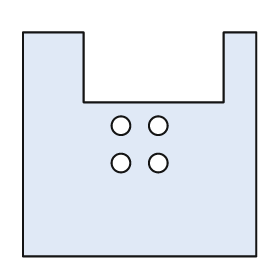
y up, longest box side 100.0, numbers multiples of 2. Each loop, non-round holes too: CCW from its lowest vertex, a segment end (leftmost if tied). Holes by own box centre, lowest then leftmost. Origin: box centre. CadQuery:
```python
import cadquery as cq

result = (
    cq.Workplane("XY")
    .moveTo(-50.0, -48.0)
    .lineTo(50.0, -48.0)
    .lineTo(50.0, 48.0)
    .lineTo(36.0, 48.0)
    .lineTo(36.0, 18.0)
    .lineTo(-24.0, 18.0)
    .lineTo(-24.0, 48.0)
    .lineTo(-50.0, 48.0)
    .close()
    .moveTo(-8.0, -8.0)
    .circle(4.0)
    .moveTo(8.0, -8.0)
    .circle(4.0)
    .moveTo(-8.0, 8.0)
    .circle(4.0)
    .moveTo(8.0, 8.0)
    .circle(4.0)
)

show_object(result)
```